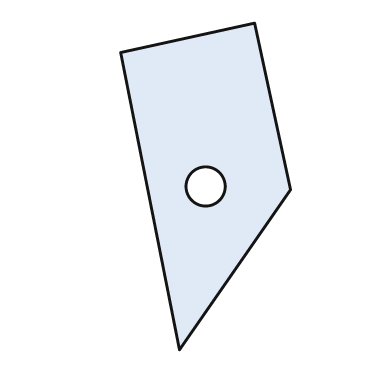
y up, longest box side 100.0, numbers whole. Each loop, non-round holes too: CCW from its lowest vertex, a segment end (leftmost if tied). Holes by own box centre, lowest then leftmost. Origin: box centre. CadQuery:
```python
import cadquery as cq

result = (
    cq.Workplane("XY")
    .moveTo(-8.0, -50.0)
    .lineTo(26.0, -1.0)
    .lineTo(15.0, 50.0)
    .lineTo(-26.0, 41.0)
    .close()
    .moveTo(0.0, 0.0)
    .circle(6.0)
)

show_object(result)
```